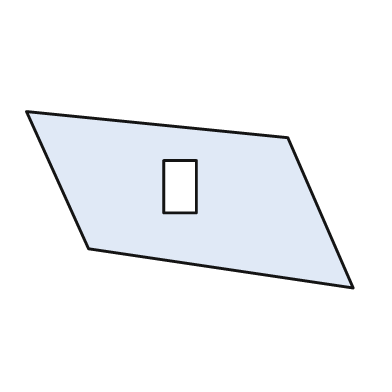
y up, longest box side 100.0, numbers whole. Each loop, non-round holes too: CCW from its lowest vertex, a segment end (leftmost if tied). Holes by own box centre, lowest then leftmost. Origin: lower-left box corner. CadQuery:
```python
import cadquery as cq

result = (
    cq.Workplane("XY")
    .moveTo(100.0, 0.0)
    .lineTo(80.0, 46.0)
    .lineTo(0.0, 54.0)
    .lineTo(19.0, 12.0)
    .close()
    .moveTo(42.0, 23.0)
    .lineTo(52.0, 23.0)
    .lineTo(52.0, 39.0)
    .lineTo(42.0, 39.0)
    .close()
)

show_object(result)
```